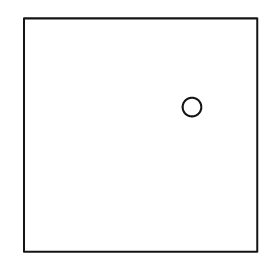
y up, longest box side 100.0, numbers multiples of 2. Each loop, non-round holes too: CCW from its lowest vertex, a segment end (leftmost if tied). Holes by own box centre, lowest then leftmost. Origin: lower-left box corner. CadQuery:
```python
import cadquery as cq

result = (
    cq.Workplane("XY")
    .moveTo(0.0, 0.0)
    .lineTo(100.0, 0.0)
    .lineTo(100.0, 100.0)
    .lineTo(0.0, 100.0)
    .close()
    .moveTo(72.0, 62.0)
    .circle(4.0)
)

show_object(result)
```